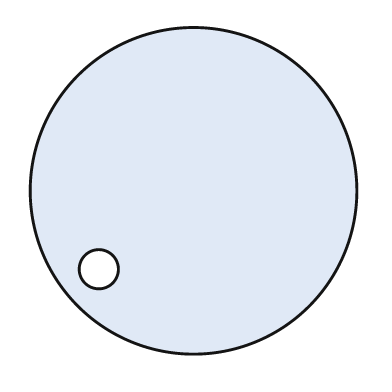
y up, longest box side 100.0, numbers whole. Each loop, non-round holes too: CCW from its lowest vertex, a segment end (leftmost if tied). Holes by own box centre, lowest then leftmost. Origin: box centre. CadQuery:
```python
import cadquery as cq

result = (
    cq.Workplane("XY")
    .moveTo(0.0, 0.0)
    .circle(50.0)
    .moveTo(-29.0, -24.0)
    .circle(6.0)
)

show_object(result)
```